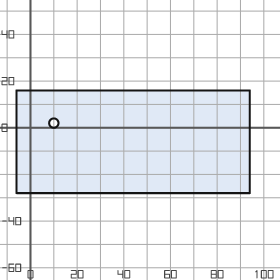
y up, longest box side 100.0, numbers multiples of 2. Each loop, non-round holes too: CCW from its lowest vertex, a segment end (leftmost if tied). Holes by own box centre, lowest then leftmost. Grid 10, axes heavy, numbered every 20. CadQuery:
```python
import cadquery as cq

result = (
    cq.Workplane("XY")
    .moveTo(-6.0, -28.0)
    .lineTo(94.0, -28.0)
    .lineTo(94.0, 16.0)
    .lineTo(-6.0, 16.0)
    .close()
    .moveTo(10.0, 2.0)
    .circle(2.0)
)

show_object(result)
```